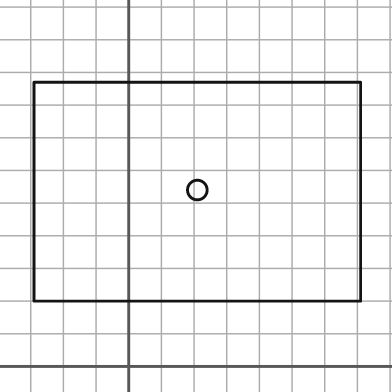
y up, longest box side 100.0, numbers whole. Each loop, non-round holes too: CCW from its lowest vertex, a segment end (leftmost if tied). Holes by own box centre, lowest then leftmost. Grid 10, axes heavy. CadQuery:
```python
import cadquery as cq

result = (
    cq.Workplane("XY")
    .moveTo(-29.0, 20.0)
    .lineTo(71.0, 20.0)
    .lineTo(71.0, 87.0)
    .lineTo(-29.0, 87.0)
    .close()
    .moveTo(21.0, 54.0)
    .circle(3.0)
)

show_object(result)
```